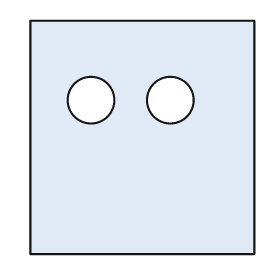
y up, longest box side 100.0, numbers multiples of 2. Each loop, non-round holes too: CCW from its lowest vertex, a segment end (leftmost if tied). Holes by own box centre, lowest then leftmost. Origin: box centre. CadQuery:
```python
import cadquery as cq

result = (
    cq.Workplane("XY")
    .moveTo(-48.0, -50.0)
    .lineTo(48.0, -50.0)
    .lineTo(48.0, 50.0)
    .lineTo(-48.0, 50.0)
    .close()
    .moveTo(-22.0, 16.0)
    .circle(10.0)
    .moveTo(12.0, 16.0)
    .circle(10.0)
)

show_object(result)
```